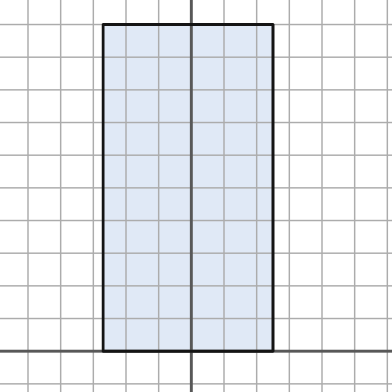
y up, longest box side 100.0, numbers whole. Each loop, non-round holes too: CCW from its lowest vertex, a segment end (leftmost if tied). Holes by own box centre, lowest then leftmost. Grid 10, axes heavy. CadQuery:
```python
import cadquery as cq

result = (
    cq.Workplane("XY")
    .moveTo(-27.0, 0.0)
    .lineTo(25.0, 0.0)
    .lineTo(25.0, 100.0)
    .lineTo(-27.0, 100.0)
    .close()
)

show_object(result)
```